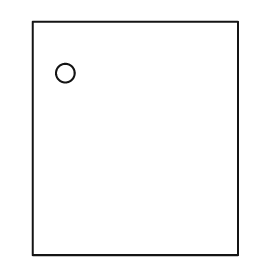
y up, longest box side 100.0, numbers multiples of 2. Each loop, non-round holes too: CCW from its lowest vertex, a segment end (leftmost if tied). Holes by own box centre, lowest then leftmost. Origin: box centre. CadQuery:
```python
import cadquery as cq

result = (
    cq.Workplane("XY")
    .moveTo(-44.0, -50.0)
    .lineTo(44.0, -50.0)
    .lineTo(44.0, 50.0)
    .lineTo(-44.0, 50.0)
    .close()
    .moveTo(-30.0, 28.0)
    .circle(4.0)
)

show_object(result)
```